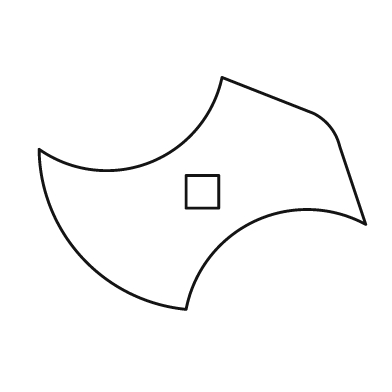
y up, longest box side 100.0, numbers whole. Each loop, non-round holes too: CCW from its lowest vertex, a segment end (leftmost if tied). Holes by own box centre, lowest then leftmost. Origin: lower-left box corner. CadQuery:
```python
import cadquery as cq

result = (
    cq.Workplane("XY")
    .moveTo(45.0, 0.0)
    .threePointArc((66.0, 27.0), (100.0, 26.0))
    .lineTo(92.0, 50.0)
    .threePointArc((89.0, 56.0), (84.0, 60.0))
    .lineTo(56.0, 71.0)
    .threePointArc((34.0, 45.0), (0.0, 49.0))
    .threePointArc((13.0, 16.0), (45.0, 0.0))
    .close()
    .moveTo(45.0, 31.0)
    .lineTo(55.0, 31.0)
    .lineTo(55.0, 41.0)
    .lineTo(45.0, 41.0)
    .close()
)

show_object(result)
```